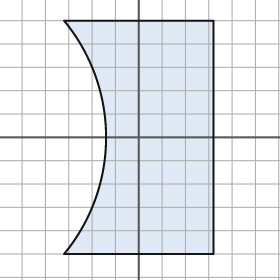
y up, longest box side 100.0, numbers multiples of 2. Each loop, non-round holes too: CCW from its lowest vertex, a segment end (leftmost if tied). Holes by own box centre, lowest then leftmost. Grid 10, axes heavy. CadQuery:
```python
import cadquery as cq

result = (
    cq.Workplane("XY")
    .moveTo(-32.0, -50.0)
    .lineTo(32.0, -50.0)
    .lineTo(32.0, 50.0)
    .lineTo(-32.0, 50.0)
    .threePointArc((-14.0, 0.0), (-32.0, -50.0))
    .close()
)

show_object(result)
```